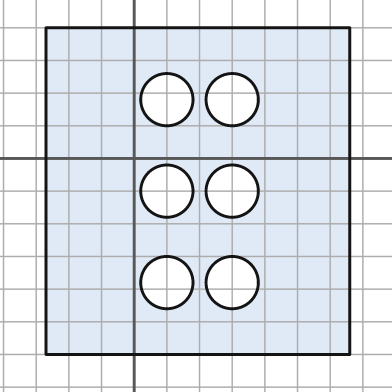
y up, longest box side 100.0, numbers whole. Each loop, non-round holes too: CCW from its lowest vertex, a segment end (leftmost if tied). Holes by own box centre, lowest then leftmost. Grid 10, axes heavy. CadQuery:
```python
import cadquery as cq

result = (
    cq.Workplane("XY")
    .moveTo(-27.0, -60.0)
    .lineTo(66.0, -60.0)
    .lineTo(66.0, 40.0)
    .lineTo(-27.0, 40.0)
    .close()
    .moveTo(10.0, -38.0)
    .circle(8.0)
    .moveTo(30.0, -38.0)
    .circle(8.0)
    .moveTo(10.0, -10.0)
    .circle(8.0)
    .moveTo(30.0, -10.0)
    .circle(8.0)
    .moveTo(10.0, 18.0)
    .circle(8.0)
    .moveTo(30.0, 18.0)
    .circle(8.0)
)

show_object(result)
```